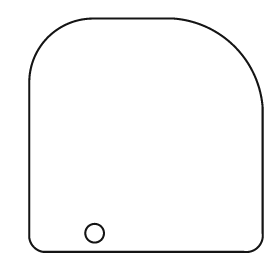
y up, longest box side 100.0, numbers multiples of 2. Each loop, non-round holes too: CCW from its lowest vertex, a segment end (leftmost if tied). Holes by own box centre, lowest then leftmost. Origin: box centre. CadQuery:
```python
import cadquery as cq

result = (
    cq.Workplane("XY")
    .moveTo(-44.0, -50.0)
    .lineTo(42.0, -50.0)
    .threePointArc((48.0, -48.0), (50.0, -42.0))
    .lineTo(50.0, 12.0)
    .threePointArc((38.0, 38.0), (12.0, 50.0))
    .lineTo(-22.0, 50.0)
    .threePointArc((-42.0, 42.0), (-50.0, 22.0))
    .lineTo(-50.0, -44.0)
    .threePointArc((-48.0, -48.0), (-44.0, -50.0))
    .close()
    .moveTo(-22.0, -42.0)
    .circle(4.0)
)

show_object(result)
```